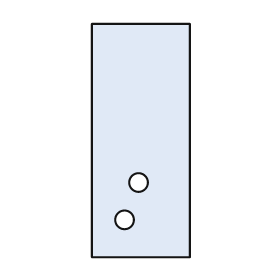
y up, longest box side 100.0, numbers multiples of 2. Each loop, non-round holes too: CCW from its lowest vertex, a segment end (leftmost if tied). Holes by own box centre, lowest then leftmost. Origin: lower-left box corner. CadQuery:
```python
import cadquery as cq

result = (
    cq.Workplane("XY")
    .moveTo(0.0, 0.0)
    .lineTo(42.0, 0.0)
    .lineTo(42.0, 100.0)
    .lineTo(0.0, 100.0)
    .close()
    .moveTo(14.0, 16.0)
    .circle(4.0)
    .moveTo(20.0, 32.0)
    .circle(4.0)
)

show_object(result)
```